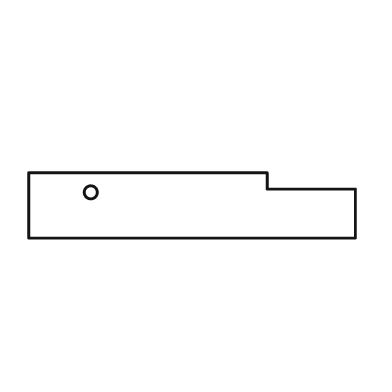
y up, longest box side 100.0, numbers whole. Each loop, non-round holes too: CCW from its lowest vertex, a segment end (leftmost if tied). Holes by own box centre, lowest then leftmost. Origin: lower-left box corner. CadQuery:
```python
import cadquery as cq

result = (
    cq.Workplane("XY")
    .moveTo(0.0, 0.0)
    .lineTo(100.0, 0.0)
    .lineTo(100.0, 15.0)
    .lineTo(73.0, 15.0)
    .lineTo(73.0, 20.0)
    .lineTo(0.0, 20.0)
    .close()
    .moveTo(19.0, 14.0)
    .circle(2.0)
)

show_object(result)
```